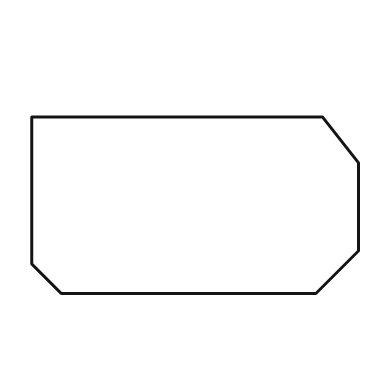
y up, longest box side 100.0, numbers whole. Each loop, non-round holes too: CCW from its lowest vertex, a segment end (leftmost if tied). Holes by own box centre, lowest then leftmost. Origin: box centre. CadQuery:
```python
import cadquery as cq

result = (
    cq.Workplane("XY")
    .moveTo(-41.0, -27.0)
    .lineTo(37.0, -27.0)
    .lineTo(50.0, -14.0)
    .lineTo(50.0, 13.0)
    .lineTo(39.0, 27.0)
    .lineTo(-50.0, 27.0)
    .lineTo(-50.0, -18.0)
    .close()
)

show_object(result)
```